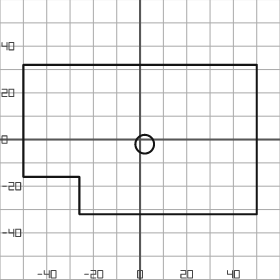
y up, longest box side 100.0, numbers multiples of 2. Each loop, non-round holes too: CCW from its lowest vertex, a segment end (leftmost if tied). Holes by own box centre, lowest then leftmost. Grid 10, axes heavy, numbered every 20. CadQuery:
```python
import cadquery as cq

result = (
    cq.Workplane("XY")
    .moveTo(-26.0, -32.0)
    .lineTo(50.0, -32.0)
    .lineTo(50.0, 32.0)
    .lineTo(-50.0, 32.0)
    .lineTo(-50.0, -16.0)
    .lineTo(-26.0, -16.0)
    .close()
    .moveTo(2.0, -2.0)
    .circle(4.0)
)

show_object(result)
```